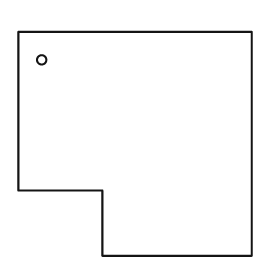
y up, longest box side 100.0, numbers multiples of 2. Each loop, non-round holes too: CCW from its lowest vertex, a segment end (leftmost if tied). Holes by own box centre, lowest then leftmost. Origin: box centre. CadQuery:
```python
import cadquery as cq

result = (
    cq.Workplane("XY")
    .moveTo(-14.0, -48.0)
    .lineTo(50.0, -48.0)
    .lineTo(50.0, 48.0)
    .lineTo(-50.0, 48.0)
    .lineTo(-50.0, -20.0)
    .lineTo(-14.0, -20.0)
    .close()
    .moveTo(-40.0, 36.0)
    .circle(2.0)
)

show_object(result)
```